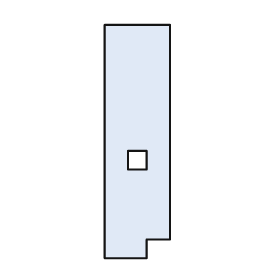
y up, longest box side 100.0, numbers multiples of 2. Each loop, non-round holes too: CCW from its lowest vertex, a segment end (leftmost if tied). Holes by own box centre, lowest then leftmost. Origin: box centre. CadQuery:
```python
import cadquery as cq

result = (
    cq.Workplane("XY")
    .moveTo(-14.0, -50.0)
    .lineTo(4.0, -50.0)
    .lineTo(4.0, -42.0)
    .lineTo(14.0, -42.0)
    .lineTo(14.0, 50.0)
    .lineTo(-14.0, 50.0)
    .close()
    .moveTo(-4.0, -12.0)
    .lineTo(4.0, -12.0)
    .lineTo(4.0, -4.0)
    .lineTo(-4.0, -4.0)
    .close()
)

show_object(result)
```